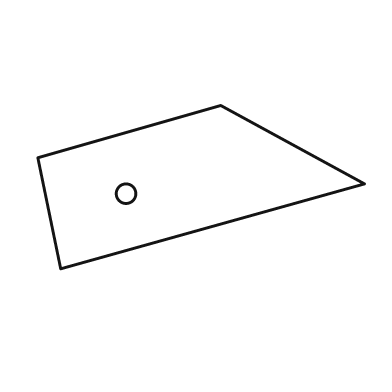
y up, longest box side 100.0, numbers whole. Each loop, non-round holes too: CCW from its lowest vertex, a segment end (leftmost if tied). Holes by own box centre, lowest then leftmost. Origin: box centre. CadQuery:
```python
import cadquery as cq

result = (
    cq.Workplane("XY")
    .moveTo(-43.0, -25.0)
    .lineTo(50.0, 1.0)
    .lineTo(6.0, 25.0)
    .lineTo(-50.0, 9.0)
    .close()
    .moveTo(-23.0, -2.0)
    .circle(3.0)
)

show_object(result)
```